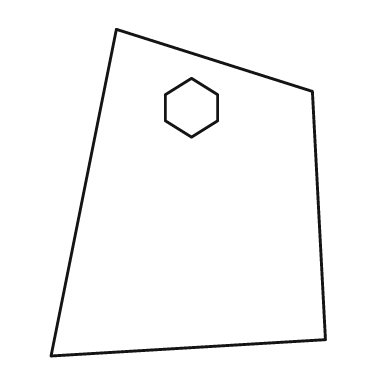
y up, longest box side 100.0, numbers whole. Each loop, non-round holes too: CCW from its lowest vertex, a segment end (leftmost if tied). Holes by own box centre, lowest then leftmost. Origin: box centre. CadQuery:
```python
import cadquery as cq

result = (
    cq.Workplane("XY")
    .moveTo(-42.0, -50.0)
    .lineTo(42.0, -45.0)
    .lineTo(38.0, 31.0)
    .lineTo(-22.0, 50.0)
    .close()
    .moveTo(1.0, 17.0)
    .lineTo(9.0, 22.0)
    .lineTo(9.0, 30.0)
    .lineTo(1.0, 35.0)
    .lineTo(-7.0, 30.0)
    .lineTo(-7.0, 22.0)
    .close()
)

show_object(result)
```